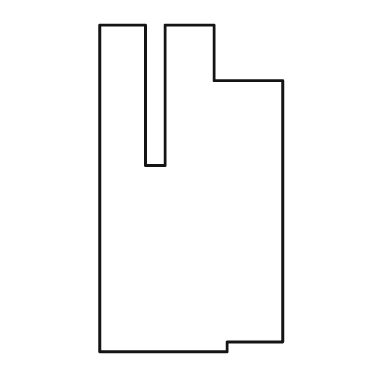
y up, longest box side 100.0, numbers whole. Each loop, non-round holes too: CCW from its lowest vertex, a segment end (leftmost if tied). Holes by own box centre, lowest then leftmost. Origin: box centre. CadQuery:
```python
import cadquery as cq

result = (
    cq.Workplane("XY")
    .moveTo(-28.0, -50.0)
    .lineTo(11.0, -50.0)
    .lineTo(11.0, -47.0)
    .lineTo(28.0, -47.0)
    .lineTo(28.0, 33.0)
    .lineTo(7.0, 33.0)
    .lineTo(7.0, 50.0)
    .lineTo(-8.0, 50.0)
    .lineTo(-8.0, 7.0)
    .lineTo(-14.0, 7.0)
    .lineTo(-14.0, 50.0)
    .lineTo(-28.0, 50.0)
    .close()
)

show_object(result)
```